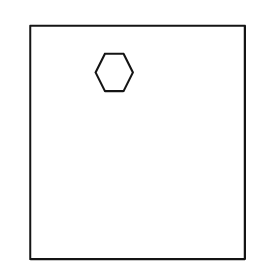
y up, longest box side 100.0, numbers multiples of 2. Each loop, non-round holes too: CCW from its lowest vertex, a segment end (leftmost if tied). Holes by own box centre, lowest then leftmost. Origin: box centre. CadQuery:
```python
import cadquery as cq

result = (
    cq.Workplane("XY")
    .moveTo(-46.0, -50.0)
    .lineTo(46.0, -50.0)
    .lineTo(46.0, 50.0)
    .lineTo(-46.0, 50.0)
    .close()
    .moveTo(-14.0, 22.0)
    .lineTo(-6.0, 22.0)
    .lineTo(-2.0, 30.0)
    .lineTo(-6.0, 38.0)
    .lineTo(-14.0, 38.0)
    .lineTo(-18.0, 30.0)
    .close()
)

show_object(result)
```